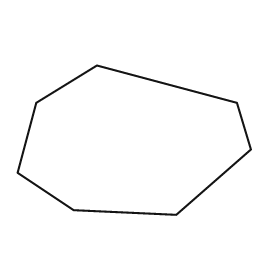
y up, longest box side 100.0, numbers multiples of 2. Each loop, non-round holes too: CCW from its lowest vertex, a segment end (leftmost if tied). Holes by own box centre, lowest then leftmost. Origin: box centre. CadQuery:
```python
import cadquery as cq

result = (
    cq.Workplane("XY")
    .moveTo(18.0, -32.0)
    .lineTo(50.0, -4.0)
    .lineTo(44.0, 16.0)
    .lineTo(-16.0, 32.0)
    .lineTo(-42.0, 16.0)
    .lineTo(-50.0, -14.0)
    .lineTo(-26.0, -30.0)
    .close()
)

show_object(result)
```